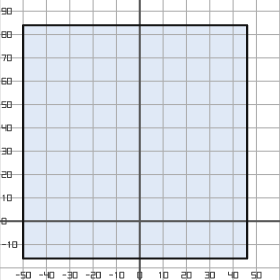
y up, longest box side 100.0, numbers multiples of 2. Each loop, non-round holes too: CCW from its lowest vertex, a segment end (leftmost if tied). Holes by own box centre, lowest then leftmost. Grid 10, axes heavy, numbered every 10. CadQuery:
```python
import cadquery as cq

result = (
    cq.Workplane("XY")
    .moveTo(-50.0, -16.0)
    .lineTo(46.0, -16.0)
    .lineTo(46.0, 84.0)
    .lineTo(-50.0, 84.0)
    .close()
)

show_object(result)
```